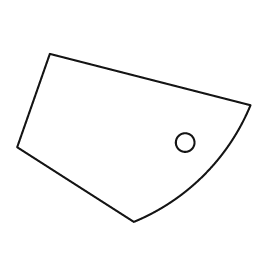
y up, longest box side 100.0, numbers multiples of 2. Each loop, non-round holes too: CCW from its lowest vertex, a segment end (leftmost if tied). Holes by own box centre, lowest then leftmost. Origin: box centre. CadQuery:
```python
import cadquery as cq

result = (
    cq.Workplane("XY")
    .moveTo(0.0, -36.0)
    .threePointArc((30.0, -16.0), (50.0, 14.0))
    .lineTo(-36.0, 36.0)
    .lineTo(-50.0, -4.0)
    .close()
    .moveTo(22.0, -2.0)
    .circle(4.0)
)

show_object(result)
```